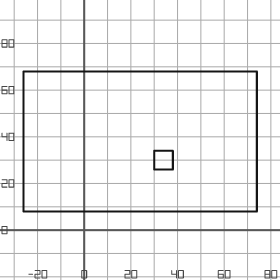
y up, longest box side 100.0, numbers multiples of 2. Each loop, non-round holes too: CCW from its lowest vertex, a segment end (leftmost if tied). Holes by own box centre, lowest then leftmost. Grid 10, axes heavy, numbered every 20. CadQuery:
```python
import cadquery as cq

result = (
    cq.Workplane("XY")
    .moveTo(-26.0, 8.0)
    .lineTo(74.0, 8.0)
    .lineTo(74.0, 68.0)
    .lineTo(-26.0, 68.0)
    .close()
    .moveTo(30.0, 26.0)
    .lineTo(38.0, 26.0)
    .lineTo(38.0, 34.0)
    .lineTo(30.0, 34.0)
    .close()
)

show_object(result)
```